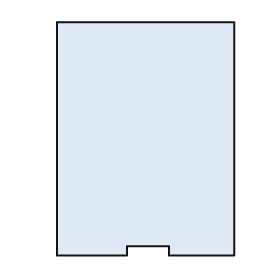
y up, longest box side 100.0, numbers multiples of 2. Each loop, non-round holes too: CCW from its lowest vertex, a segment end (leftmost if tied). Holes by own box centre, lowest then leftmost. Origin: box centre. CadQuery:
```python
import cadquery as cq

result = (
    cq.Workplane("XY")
    .moveTo(-38.0, -50.0)
    .lineTo(-8.0, -50.0)
    .lineTo(-8.0, -46.0)
    .lineTo(10.0, -46.0)
    .lineTo(10.0, -50.0)
    .lineTo(38.0, -50.0)
    .lineTo(38.0, 50.0)
    .lineTo(-38.0, 50.0)
    .close()
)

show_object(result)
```